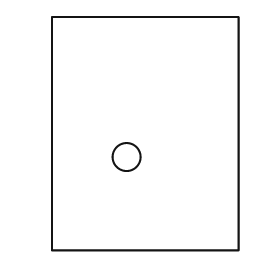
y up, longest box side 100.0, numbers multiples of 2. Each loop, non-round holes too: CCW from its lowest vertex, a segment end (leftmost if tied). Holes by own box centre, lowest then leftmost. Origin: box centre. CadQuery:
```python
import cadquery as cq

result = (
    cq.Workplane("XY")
    .moveTo(-40.0, -50.0)
    .lineTo(40.0, -50.0)
    .lineTo(40.0, 50.0)
    .lineTo(-40.0, 50.0)
    .close()
    .moveTo(-8.0, -10.0)
    .circle(6.0)
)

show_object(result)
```